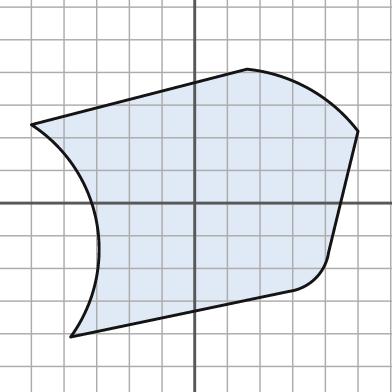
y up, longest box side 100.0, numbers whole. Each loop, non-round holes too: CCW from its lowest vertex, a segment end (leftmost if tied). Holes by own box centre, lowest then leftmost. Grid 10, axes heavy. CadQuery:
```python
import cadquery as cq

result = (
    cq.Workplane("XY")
    .moveTo(-38.0, -41.0)
    .lineTo(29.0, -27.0)
    .threePointArc((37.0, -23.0), (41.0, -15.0))
    .lineTo(50.0, 22.0)
    .threePointArc((35.0, 35.0), (16.0, 41.0))
    .lineTo(-50.0, 24.0)
    .threePointArc((-30.0, -6.0), (-38.0, -41.0))
    .close()
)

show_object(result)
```